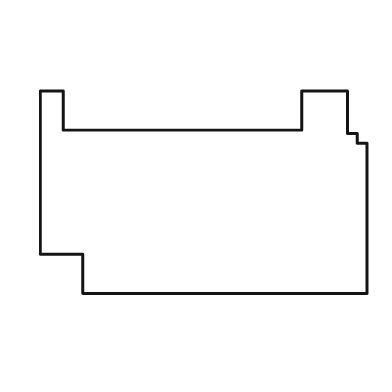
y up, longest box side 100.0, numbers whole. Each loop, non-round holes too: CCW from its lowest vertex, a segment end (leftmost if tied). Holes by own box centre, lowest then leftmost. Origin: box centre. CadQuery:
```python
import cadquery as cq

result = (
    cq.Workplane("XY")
    .moveTo(-37.0, -31.0)
    .lineTo(50.0, -31.0)
    .lineTo(50.0, 15.0)
    .lineTo(47.0, 15.0)
    .lineTo(47.0, 18.0)
    .lineTo(44.0, 18.0)
    .lineTo(44.0, 31.0)
    .lineTo(30.0, 31.0)
    .lineTo(30.0, 19.0)
    .lineTo(-43.0, 19.0)
    .lineTo(-43.0, 31.0)
    .lineTo(-50.0, 31.0)
    .lineTo(-50.0, -19.0)
    .lineTo(-37.0, -19.0)
    .close()
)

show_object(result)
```